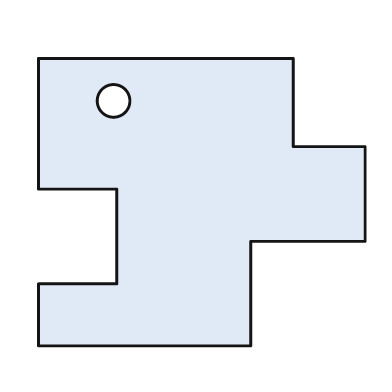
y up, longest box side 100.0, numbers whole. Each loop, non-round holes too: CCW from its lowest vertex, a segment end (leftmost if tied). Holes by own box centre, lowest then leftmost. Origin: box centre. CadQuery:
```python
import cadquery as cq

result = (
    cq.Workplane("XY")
    .moveTo(-50.0, -44.0)
    .lineTo(15.0, -44.0)
    .lineTo(15.0, -12.0)
    .lineTo(50.0, -12.0)
    .lineTo(50.0, 17.0)
    .lineTo(28.0, 17.0)
    .lineTo(28.0, 44.0)
    .lineTo(-50.0, 44.0)
    .lineTo(-50.0, 4.0)
    .lineTo(-26.0, 4.0)
    .lineTo(-26.0, -25.0)
    .lineTo(-50.0, -25.0)
    .close()
    .moveTo(-27.0, 31.0)
    .circle(5.0)
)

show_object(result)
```